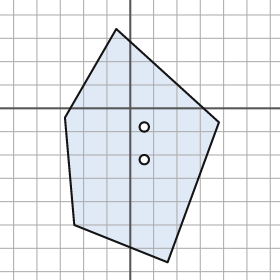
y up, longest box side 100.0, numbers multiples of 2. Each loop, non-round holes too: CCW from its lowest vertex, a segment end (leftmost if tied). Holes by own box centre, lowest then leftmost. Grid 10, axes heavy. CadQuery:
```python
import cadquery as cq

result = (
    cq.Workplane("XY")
    .moveTo(16.0, -66.0)
    .lineTo(38.0, -6.0)
    .lineTo(-6.0, 34.0)
    .lineTo(-28.0, -4.0)
    .lineTo(-24.0, -50.0)
    .close()
    .moveTo(6.0, -22.0)
    .circle(2.0)
    .moveTo(6.0, -8.0)
    .circle(2.0)
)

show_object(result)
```